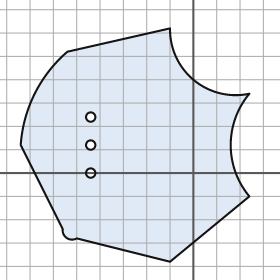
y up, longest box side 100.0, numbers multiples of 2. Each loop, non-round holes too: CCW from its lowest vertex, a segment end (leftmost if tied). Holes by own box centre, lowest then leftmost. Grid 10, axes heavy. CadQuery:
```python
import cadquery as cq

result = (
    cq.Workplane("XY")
    .moveTo(-10.0, -38.0)
    .lineTo(24.0, -10.0)
    .threePointArc((16.0, 12.0), (24.0, 34.0))
    .threePointArc((0.0, 40.0), (-10.0, 62.0))
    .lineTo(-54.0, 52.0)
    .threePointArc((-68.0, 34.0), (-74.0, 12.0))
    .lineTo(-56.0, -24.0)
    .threePointArc((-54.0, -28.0), (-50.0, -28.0))
    .close()
    .moveTo(-44.0, 0.0)
    .circle(2.0)
    .moveTo(-44.0, 12.0)
    .circle(2.0)
    .moveTo(-44.0, 24.0)
    .circle(2.0)
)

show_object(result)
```